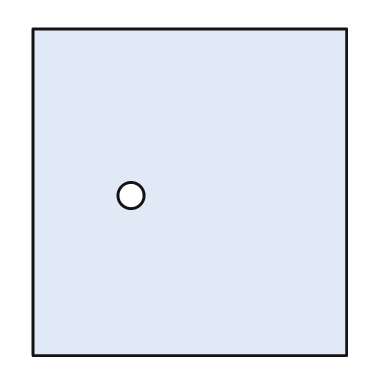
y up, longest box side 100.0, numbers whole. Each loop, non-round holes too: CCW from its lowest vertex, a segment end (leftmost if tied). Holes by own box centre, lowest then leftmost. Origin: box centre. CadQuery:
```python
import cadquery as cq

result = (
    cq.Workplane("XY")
    .moveTo(-48.0, -50.0)
    .lineTo(48.0, -50.0)
    .lineTo(48.0, 50.0)
    .lineTo(-48.0, 50.0)
    .close()
    .moveTo(-18.0, -1.0)
    .circle(4.0)
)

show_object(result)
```